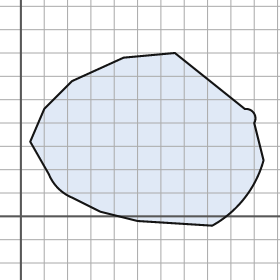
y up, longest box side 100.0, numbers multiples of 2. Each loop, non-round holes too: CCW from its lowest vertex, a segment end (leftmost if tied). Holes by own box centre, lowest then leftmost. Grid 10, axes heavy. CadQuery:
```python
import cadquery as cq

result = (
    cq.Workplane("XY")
    .moveTo(82.0, -4.0)
    .threePointArc((96.0, 8.0), (104.0, 24.0))
    .lineTo(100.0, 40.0)
    .threePointArc((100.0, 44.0), (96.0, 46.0))
    .lineTo(66.0, 70.0)
    .lineTo(44.0, 68.0)
    .lineTo(22.0, 58.0)
    .lineTo(10.0, 46.0)
    .lineTo(4.0, 32.0)
    .lineTo(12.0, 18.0)
    .threePointArc((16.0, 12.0), (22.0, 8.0))
    .lineTo(34.0, 2.0)
    .lineTo(50.0, -2.0)
    .close()
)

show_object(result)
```